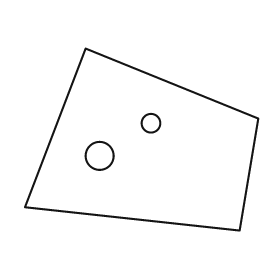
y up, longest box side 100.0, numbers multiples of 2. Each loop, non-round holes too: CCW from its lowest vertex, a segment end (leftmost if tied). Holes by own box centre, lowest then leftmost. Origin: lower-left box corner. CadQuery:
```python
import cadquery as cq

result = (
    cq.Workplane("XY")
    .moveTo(92.0, 0.0)
    .lineTo(100.0, 48.0)
    .lineTo(26.0, 78.0)
    .lineTo(0.0, 10.0)
    .close()
    .moveTo(32.0, 32.0)
    .circle(6.0)
    .moveTo(54.0, 46.0)
    .circle(4.0)
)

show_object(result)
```